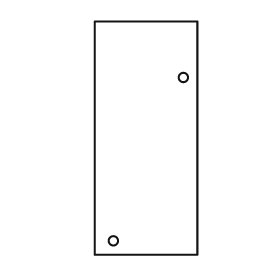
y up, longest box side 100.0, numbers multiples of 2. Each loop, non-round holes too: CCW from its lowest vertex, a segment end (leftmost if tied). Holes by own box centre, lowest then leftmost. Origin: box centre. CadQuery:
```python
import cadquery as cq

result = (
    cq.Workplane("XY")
    .moveTo(-22.0, -50.0)
    .lineTo(22.0, -50.0)
    .lineTo(22.0, 50.0)
    .lineTo(-22.0, 50.0)
    .close()
    .moveTo(-14.0, -44.0)
    .circle(2.0)
    .moveTo(16.0, 26.0)
    .circle(2.0)
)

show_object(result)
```